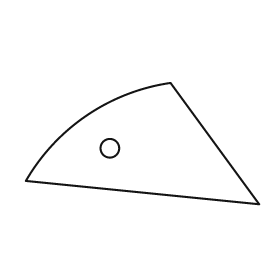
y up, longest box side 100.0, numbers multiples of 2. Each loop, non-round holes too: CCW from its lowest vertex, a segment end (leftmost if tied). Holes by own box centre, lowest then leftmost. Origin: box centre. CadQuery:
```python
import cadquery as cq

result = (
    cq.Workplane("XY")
    .moveTo(50.0, -26.0)
    .lineTo(12.0, 26.0)
    .threePointArc((-24.0, 12.0), (-50.0, -16.0))
    .close()
    .moveTo(-14.0, -2.0)
    .circle(4.0)
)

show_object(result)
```